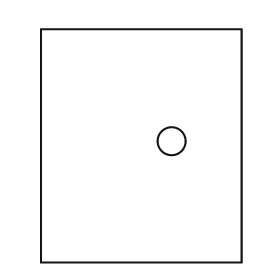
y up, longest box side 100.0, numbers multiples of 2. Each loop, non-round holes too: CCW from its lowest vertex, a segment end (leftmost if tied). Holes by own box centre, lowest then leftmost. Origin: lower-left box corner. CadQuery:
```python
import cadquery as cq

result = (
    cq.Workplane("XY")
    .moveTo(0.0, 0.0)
    .lineTo(86.0, 0.0)
    .lineTo(86.0, 100.0)
    .lineTo(0.0, 100.0)
    .close()
    .moveTo(56.0, 52.0)
    .circle(6.0)
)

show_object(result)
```